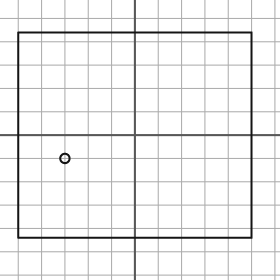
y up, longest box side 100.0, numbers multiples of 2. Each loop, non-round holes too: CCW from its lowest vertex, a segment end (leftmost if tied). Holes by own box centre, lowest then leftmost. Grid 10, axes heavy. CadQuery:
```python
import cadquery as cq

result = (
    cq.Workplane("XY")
    .moveTo(-50.0, -44.0)
    .lineTo(50.0, -44.0)
    .lineTo(50.0, 44.0)
    .lineTo(-50.0, 44.0)
    .close()
    .moveTo(-30.0, -10.0)
    .circle(2.0)
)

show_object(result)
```